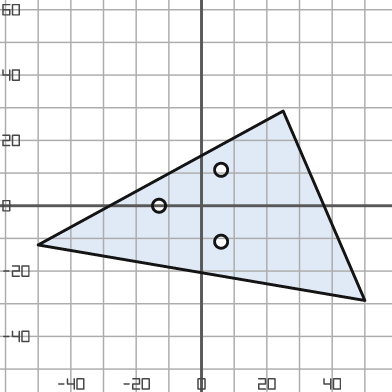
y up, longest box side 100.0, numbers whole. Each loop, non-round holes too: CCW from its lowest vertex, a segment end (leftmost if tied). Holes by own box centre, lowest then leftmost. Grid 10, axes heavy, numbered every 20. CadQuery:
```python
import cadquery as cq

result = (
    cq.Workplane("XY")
    .moveTo(50.0, -29.0)
    .lineTo(25.0, 29.0)
    .lineTo(-50.0, -12.0)
    .close()
    .moveTo(6.0, -11.0)
    .circle(2.0)
    .moveTo(-13.0, 0.0)
    .circle(2.0)
    .moveTo(6.0, 11.0)
    .circle(2.0)
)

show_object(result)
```